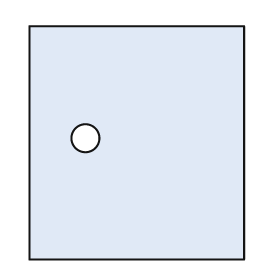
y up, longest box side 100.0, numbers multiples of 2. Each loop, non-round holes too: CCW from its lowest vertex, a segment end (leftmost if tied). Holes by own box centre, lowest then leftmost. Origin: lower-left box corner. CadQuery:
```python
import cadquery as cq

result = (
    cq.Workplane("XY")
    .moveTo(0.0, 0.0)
    .lineTo(92.0, 0.0)
    .lineTo(92.0, 100.0)
    .lineTo(0.0, 100.0)
    .close()
    .moveTo(24.0, 52.0)
    .circle(6.0)
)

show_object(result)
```